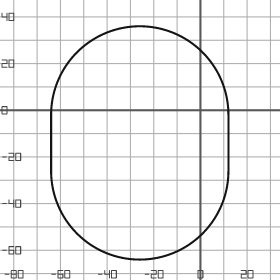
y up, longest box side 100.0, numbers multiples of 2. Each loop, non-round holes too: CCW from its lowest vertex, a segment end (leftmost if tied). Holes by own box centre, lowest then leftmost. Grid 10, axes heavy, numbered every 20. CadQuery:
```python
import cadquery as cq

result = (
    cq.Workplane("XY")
    .moveTo(-64.0, -26.0)
    .threePointArc((-26.0, -64.0), (12.0, -26.0))
    .lineTo(12.0, -2.0)
    .threePointArc((-26.0, 36.0), (-64.0, -2.0))
    .close()
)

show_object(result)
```